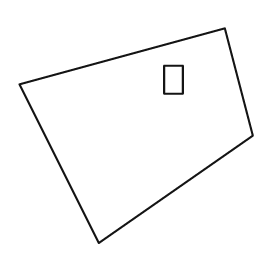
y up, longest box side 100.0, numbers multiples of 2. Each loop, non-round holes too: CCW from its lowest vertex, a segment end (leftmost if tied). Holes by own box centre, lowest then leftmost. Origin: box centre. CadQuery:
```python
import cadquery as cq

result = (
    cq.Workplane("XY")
    .moveTo(-16.0, -46.0)
    .lineTo(50.0, 0.0)
    .lineTo(38.0, 46.0)
    .lineTo(-50.0, 22.0)
    .close()
    .moveTo(12.0, 18.0)
    .lineTo(20.0, 18.0)
    .lineTo(20.0, 30.0)
    .lineTo(12.0, 30.0)
    .close()
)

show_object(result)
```